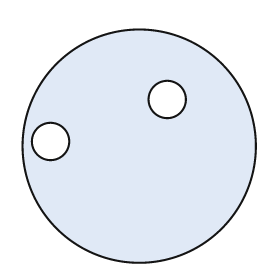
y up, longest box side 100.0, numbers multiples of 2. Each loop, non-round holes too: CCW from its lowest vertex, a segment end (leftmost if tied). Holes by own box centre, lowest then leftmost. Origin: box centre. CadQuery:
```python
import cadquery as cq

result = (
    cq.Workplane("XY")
    .moveTo(0.0, 0.0)
    .circle(50.0)
    .moveTo(-38.0, 2.0)
    .circle(8.0)
    .moveTo(12.0, 20.0)
    .circle(8.0)
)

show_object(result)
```